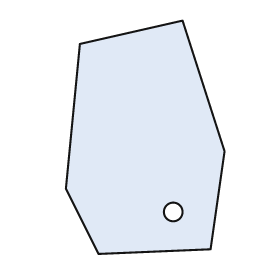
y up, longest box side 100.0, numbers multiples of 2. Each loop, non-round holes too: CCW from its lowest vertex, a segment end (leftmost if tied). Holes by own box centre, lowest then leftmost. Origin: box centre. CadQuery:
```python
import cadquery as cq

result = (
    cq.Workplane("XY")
    .moveTo(-20.0, -50.0)
    .lineTo(28.0, -48.0)
    .lineTo(34.0, -6.0)
    .lineTo(16.0, 50.0)
    .lineTo(-28.0, 40.0)
    .lineTo(-34.0, -22.0)
    .close()
    .moveTo(12.0, -32.0)
    .circle(4.0)
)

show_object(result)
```